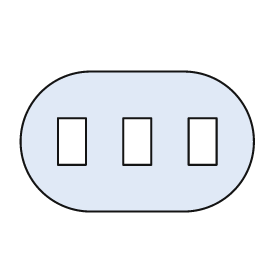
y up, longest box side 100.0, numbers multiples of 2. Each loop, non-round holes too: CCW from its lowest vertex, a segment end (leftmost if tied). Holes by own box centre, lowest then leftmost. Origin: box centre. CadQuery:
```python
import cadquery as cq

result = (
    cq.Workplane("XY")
    .moveTo(-20.0, -30.0)
    .lineTo(20.0, -30.0)
    .threePointArc((50.0, 0.0), (20.0, 30.0))
    .lineTo(-20.0, 30.0)
    .threePointArc((-50.0, 0.0), (-20.0, -30.0))
    .close()
    .moveTo(-34.0, -10.0)
    .lineTo(-22.0, -10.0)
    .lineTo(-22.0, 10.0)
    .lineTo(-34.0, 10.0)
    .close()
    .moveTo(-6.0, -10.0)
    .lineTo(6.0, -10.0)
    .lineTo(6.0, 10.0)
    .lineTo(-6.0, 10.0)
    .close()
    .moveTo(22.0, -10.0)
    .lineTo(34.0, -10.0)
    .lineTo(34.0, 10.0)
    .lineTo(22.0, 10.0)
    .close()
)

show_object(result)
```